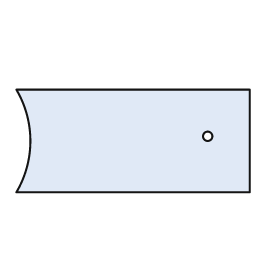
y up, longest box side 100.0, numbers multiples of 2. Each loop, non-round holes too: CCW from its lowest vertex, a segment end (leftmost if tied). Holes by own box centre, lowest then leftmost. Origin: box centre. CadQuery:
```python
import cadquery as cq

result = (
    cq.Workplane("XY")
    .moveTo(-50.0, -22.0)
    .lineTo(50.0, -22.0)
    .lineTo(50.0, 22.0)
    .lineTo(-50.0, 22.0)
    .threePointArc((-44.0, 0.0), (-50.0, -22.0))
    .close()
    .moveTo(32.0, 2.0)
    .circle(2.0)
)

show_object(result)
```